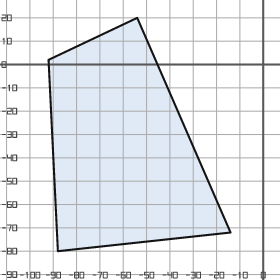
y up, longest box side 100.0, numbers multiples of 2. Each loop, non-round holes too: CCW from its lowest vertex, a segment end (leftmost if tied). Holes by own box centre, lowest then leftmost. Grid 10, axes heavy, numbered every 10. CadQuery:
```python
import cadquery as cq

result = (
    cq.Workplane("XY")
    .moveTo(-88.0, -80.0)
    .lineTo(-14.0, -72.0)
    .lineTo(-54.0, 20.0)
    .lineTo(-92.0, 2.0)
    .close()
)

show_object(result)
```